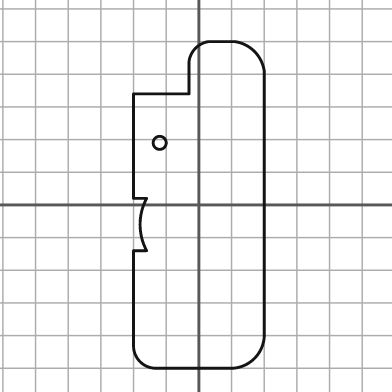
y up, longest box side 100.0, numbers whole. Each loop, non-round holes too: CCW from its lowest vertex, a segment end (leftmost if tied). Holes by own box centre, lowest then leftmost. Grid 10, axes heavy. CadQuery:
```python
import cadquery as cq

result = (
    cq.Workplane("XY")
    .moveTo(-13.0, -50.0)
    .lineTo(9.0, -50.0)
    .threePointArc((17.0, -47.0), (20.0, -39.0))
    .lineTo(20.0, 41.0)
    .threePointArc((17.0, 47.0), (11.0, 50.0))
    .lineTo(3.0, 50.0)
    .threePointArc((-1.0, 48.0), (-3.0, 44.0))
    .lineTo(-3.0, 34.0)
    .lineTo(-20.0, 34.0)
    .lineTo(-20.0, 2.0)
    .lineTo(-16.0, 2.0)
    .threePointArc((-18.0, -6.0), (-16.0, -14.0))
    .lineTo(-20.0, -14.0)
    .lineTo(-20.0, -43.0)
    .threePointArc((-18.0, -48.0), (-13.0, -50.0))
    .close()
    .moveTo(-12.0, 19.0)
    .circle(2.0)
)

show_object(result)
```